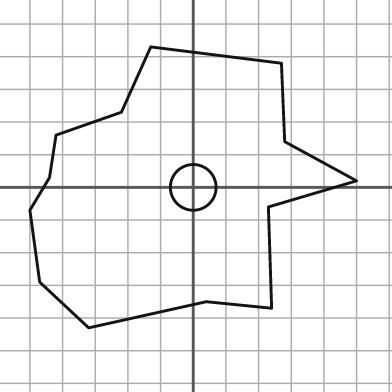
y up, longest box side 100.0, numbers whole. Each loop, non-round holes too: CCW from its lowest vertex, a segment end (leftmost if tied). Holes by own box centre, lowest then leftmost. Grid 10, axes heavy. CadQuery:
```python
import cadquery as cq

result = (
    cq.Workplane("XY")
    .moveTo(-32.0, -43.0)
    .lineTo(4.0, -35.0)
    .lineTo(24.0, -37.0)
    .lineTo(23.0, -6.0)
    .lineTo(50.0, 2.0)
    .lineTo(28.0, 14.0)
    .lineTo(27.0, 38.0)
    .lineTo(-13.0, 43.0)
    .lineTo(-22.0, 23.0)
    .lineTo(-42.0, 16.0)
    .lineTo(-44.0, 3.0)
    .lineTo(-50.0, -7.0)
    .lineTo(-47.0, -29.0)
    .close()
    .moveTo(0.0, 0.0)
    .circle(7.0)
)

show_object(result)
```